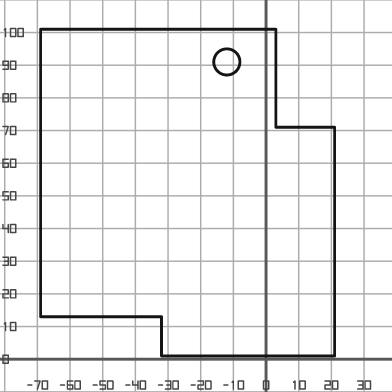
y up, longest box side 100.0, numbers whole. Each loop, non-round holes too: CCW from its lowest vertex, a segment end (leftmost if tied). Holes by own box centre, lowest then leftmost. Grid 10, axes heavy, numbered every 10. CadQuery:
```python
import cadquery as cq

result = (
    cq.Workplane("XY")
    .moveTo(-32.0, 1.0)
    .lineTo(21.0, 1.0)
    .lineTo(21.0, 71.0)
    .lineTo(3.0, 71.0)
    .lineTo(3.0, 101.0)
    .lineTo(-69.0, 101.0)
    .lineTo(-69.0, 13.0)
    .lineTo(-32.0, 13.0)
    .close()
    .moveTo(-12.0, 91.0)
    .circle(4.0)
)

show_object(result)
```